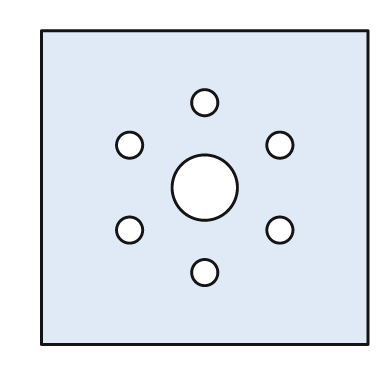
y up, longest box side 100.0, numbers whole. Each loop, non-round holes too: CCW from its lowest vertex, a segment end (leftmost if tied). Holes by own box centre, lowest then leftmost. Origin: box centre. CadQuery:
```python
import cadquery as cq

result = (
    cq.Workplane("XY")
    .moveTo(-50.0, -48.0)
    .lineTo(50.0, -48.0)
    .lineTo(50.0, 48.0)
    .lineTo(-50.0, 48.0)
    .close()
    .moveTo(0.0, -26.0)
    .circle(4.0)
    .moveTo(-23.0, -13.0)
    .circle(4.0)
    .moveTo(23.0, -13.0)
    .circle(4.0)
    .moveTo(0.0, 0.0)
    .circle(10.0)
    .moveTo(-23.0, 13.0)
    .circle(4.0)
    .moveTo(23.0, 13.0)
    .circle(4.0)
    .moveTo(0.0, 26.0)
    .circle(4.0)
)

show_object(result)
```